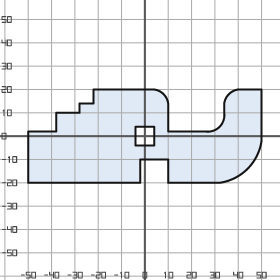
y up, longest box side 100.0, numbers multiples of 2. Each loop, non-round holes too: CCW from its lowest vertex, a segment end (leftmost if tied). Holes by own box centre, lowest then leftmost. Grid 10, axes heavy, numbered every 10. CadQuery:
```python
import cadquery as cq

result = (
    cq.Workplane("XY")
    .moveTo(-50.0, -20.0)
    .lineTo(-2.0, -20.0)
    .lineTo(-2.0, -10.0)
    .lineTo(10.0, -10.0)
    .lineTo(10.0, -20.0)
    .lineTo(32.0, -20.0)
    .threePointArc((44.0, -14.0), (50.0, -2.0))
    .lineTo(50.0, 20.0)
    .lineTo(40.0, 20.0)
    .threePointArc((36.0, 18.0), (34.0, 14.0))
    .lineTo(34.0, 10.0)
    .threePointArc((32.0, 4.0), (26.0, 2.0))
    .lineTo(10.0, 2.0)
    .lineTo(10.0, 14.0)
    .threePointArc((8.0, 18.0), (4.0, 20.0))
    .lineTo(-22.0, 20.0)
    .lineTo(-22.0, 14.0)
    .lineTo(-28.0, 14.0)
    .lineTo(-28.0, 10.0)
    .lineTo(-38.0, 10.0)
    .lineTo(-38.0, 2.0)
    .lineTo(-50.0, 2.0)
    .close()
    .moveTo(-4.0, -4.0)
    .lineTo(4.0, -4.0)
    .lineTo(4.0, 4.0)
    .lineTo(-4.0, 4.0)
    .close()
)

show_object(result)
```